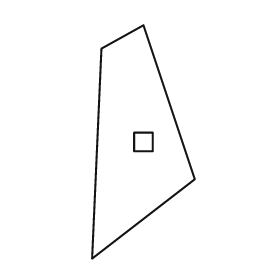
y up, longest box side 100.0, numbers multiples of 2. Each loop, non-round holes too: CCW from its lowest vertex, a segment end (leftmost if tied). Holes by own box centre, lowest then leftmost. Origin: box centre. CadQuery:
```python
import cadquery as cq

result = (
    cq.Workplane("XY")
    .moveTo(-22.0, -50.0)
    .lineTo(22.0, -16.0)
    .lineTo(0.0, 50.0)
    .lineTo(-18.0, 40.0)
    .close()
    .moveTo(-4.0, -4.0)
    .lineTo(4.0, -4.0)
    .lineTo(4.0, 4.0)
    .lineTo(-4.0, 4.0)
    .close()
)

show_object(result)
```